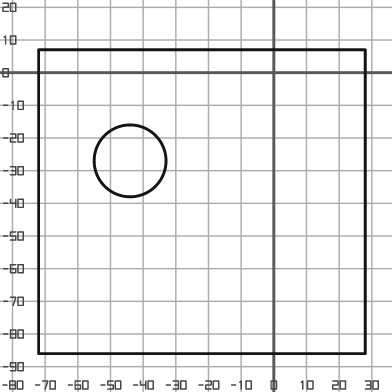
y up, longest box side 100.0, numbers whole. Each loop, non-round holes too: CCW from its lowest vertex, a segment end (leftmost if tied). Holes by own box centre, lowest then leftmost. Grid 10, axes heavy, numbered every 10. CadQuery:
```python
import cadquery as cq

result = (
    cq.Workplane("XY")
    .moveTo(-72.0, -86.0)
    .lineTo(28.0, -86.0)
    .lineTo(28.0, 7.0)
    .lineTo(-72.0, 7.0)
    .close()
    .moveTo(-44.0, -27.0)
    .circle(11.0)
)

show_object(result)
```